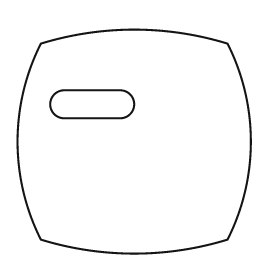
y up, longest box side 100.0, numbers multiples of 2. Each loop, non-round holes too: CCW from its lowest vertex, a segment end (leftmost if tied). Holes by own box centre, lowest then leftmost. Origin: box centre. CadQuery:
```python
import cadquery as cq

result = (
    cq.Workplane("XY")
    .moveTo(-40.0, -42.0)
    .threePointArc((0.0, -48.0), (40.0, -42.0))
    .threePointArc((50.0, 0.0), (40.0, 42.0))
    .threePointArc((0.0, 48.0), (-40.0, 42.0))
    .threePointArc((-50.0, 0.0), (-40.0, -42.0))
    .close()
    .moveTo(-30.0, 10.0)
    .lineTo(-6.0, 10.0)
    .threePointArc((0.0, 16.0), (-6.0, 22.0))
    .lineTo(-30.0, 22.0)
    .threePointArc((-36.0, 16.0), (-30.0, 10.0))
    .close()
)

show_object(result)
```